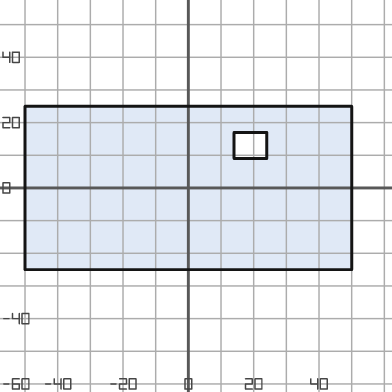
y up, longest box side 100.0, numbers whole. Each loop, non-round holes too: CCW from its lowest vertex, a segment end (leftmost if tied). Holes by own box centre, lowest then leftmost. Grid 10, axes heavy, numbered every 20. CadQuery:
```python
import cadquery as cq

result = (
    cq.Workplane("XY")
    .moveTo(-50.0, -25.0)
    .lineTo(50.0, -25.0)
    .lineTo(50.0, 25.0)
    .lineTo(-50.0, 25.0)
    .close()
    .moveTo(14.0, 9.0)
    .lineTo(24.0, 9.0)
    .lineTo(24.0, 17.0)
    .lineTo(14.0, 17.0)
    .close()
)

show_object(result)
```